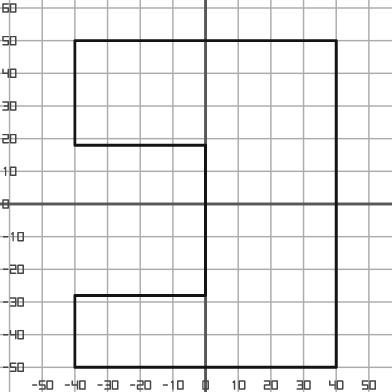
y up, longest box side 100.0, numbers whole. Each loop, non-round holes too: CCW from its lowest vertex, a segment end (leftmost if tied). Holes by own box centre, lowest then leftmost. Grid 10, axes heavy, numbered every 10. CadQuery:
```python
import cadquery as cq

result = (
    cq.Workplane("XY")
    .moveTo(-40.0, -50.0)
    .lineTo(40.0, -50.0)
    .lineTo(40.0, 50.0)
    .lineTo(-40.0, 50.0)
    .lineTo(-40.0, 18.0)
    .lineTo(0.0, 18.0)
    .lineTo(0.0, -28.0)
    .lineTo(-40.0, -28.0)
    .close()
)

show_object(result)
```